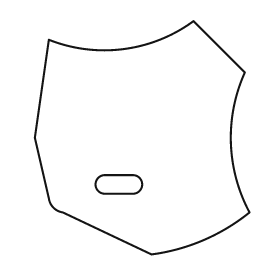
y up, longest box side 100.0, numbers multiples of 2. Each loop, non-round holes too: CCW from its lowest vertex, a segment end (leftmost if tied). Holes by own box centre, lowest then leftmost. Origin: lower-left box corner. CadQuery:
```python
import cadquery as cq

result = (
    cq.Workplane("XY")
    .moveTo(50.0, 0.0)
    .threePointArc((72.0, 6.0), (92.0, 18.0))
    .threePointArc((84.0, 48.0), (90.0, 78.0))
    .lineTo(68.0, 100.0)
    .threePointArc((38.0, 88.0), (6.0, 92.0))
    .lineTo(0.0, 50.0)
    .lineTo(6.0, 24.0)
    .threePointArc((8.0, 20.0), (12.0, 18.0))
    .close()
    .moveTo(30.0, 26.0)
    .lineTo(42.0, 26.0)
    .threePointArc((46.0, 30.0), (42.0, 34.0))
    .lineTo(30.0, 34.0)
    .threePointArc((26.0, 30.0), (30.0, 26.0))
    .close()
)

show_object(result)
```